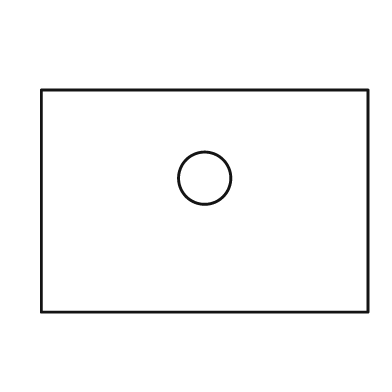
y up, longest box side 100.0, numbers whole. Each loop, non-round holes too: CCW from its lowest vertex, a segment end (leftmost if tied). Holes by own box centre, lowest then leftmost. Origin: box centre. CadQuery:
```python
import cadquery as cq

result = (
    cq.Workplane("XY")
    .moveTo(-50.0, -34.0)
    .lineTo(50.0, -34.0)
    .lineTo(50.0, 34.0)
    .lineTo(-50.0, 34.0)
    .close()
    .moveTo(0.0, 7.0)
    .circle(8.0)
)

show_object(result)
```